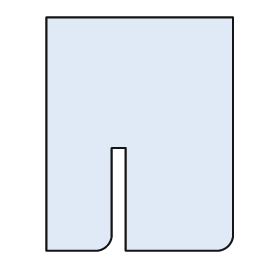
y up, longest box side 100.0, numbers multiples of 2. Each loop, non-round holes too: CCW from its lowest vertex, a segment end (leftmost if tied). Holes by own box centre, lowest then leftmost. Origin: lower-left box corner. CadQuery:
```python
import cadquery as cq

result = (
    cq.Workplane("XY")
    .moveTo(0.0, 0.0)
    .lineTo(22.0, 0.0)
    .threePointArc((26.0, 2.0), (28.0, 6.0))
    .lineTo(28.0, 44.0)
    .lineTo(34.0, 44.0)
    .lineTo(34.0, 0.0)
    .lineTo(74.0, 0.0)
    .threePointArc((78.0, 2.0), (80.0, 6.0))
    .lineTo(80.0, 100.0)
    .lineTo(0.0, 100.0)
    .close()
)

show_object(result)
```